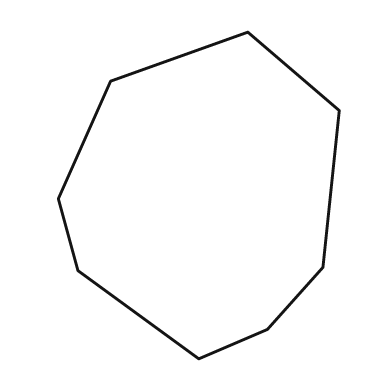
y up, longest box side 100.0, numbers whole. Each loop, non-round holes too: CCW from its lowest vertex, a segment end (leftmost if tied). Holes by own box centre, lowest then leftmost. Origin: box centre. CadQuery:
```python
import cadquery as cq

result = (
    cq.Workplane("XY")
    .moveTo(0.0, -50.0)
    .lineTo(21.0, -41.0)
    .lineTo(38.0, -22.0)
    .lineTo(43.0, 26.0)
    .lineTo(15.0, 50.0)
    .lineTo(-27.0, 35.0)
    .lineTo(-43.0, -1.0)
    .lineTo(-37.0, -23.0)
    .close()
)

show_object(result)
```